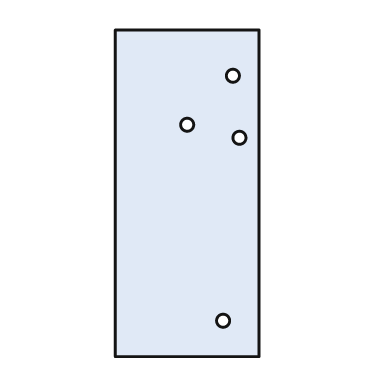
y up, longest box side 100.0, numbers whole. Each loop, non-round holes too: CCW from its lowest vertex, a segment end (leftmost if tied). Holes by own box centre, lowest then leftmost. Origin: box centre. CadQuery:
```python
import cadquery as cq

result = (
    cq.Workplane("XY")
    .moveTo(-22.0, -50.0)
    .lineTo(22.0, -50.0)
    .lineTo(22.0, 50.0)
    .lineTo(-22.0, 50.0)
    .close()
    .moveTo(11.0, -39.0)
    .circle(2.0)
    .moveTo(16.0, 17.0)
    .circle(2.0)
    .moveTo(0.0, 21.0)
    .circle(2.0)
    .moveTo(14.0, 36.0)
    .circle(2.0)
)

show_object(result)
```